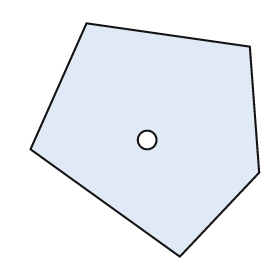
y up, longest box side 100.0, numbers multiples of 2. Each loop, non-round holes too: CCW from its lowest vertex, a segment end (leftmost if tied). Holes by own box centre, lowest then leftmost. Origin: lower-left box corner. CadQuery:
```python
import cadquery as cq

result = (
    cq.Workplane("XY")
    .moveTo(64.0, 0.0)
    .lineTo(98.0, 36.0)
    .lineTo(94.0, 90.0)
    .lineTo(24.0, 100.0)
    .lineTo(0.0, 46.0)
    .close()
    .moveTo(50.0, 50.0)
    .circle(4.0)
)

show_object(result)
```